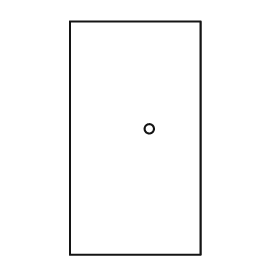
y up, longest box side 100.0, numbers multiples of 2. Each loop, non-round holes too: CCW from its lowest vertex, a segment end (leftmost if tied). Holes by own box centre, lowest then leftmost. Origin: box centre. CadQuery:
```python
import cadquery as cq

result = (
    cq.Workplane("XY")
    .moveTo(-28.0, -50.0)
    .lineTo(28.0, -50.0)
    .lineTo(28.0, 50.0)
    .lineTo(-28.0, 50.0)
    .close()
    .moveTo(6.0, 4.0)
    .circle(2.0)
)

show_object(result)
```